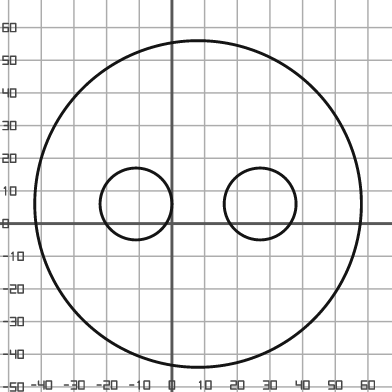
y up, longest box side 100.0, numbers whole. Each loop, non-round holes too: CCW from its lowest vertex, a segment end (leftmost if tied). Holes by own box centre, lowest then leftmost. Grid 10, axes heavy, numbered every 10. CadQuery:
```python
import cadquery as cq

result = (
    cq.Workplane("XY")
    .moveTo(8.0, 6.0)
    .circle(50.0)
    .moveTo(-11.0, 6.0)
    .circle(11.0)
    .moveTo(27.0, 6.0)
    .circle(11.0)
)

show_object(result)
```